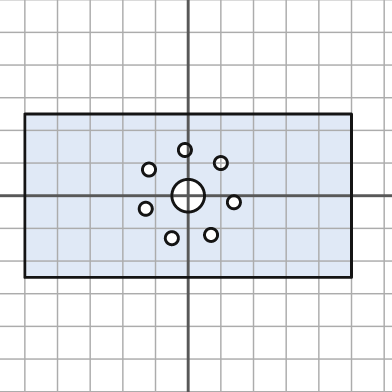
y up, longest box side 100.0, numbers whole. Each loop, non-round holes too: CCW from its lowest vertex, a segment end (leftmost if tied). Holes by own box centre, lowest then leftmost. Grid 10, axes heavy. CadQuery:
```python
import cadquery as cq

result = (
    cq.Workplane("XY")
    .moveTo(-50.0, -25.0)
    .lineTo(50.0, -25.0)
    .lineTo(50.0, 25.0)
    .lineTo(-50.0, 25.0)
    .close()
    .moveTo(-5.0, -13.0)
    .circle(2.0)
    .moveTo(7.0, -12.0)
    .circle(2.0)
    .moveTo(-13.0, -4.0)
    .circle(2.0)
    .moveTo(14.0, -2.0)
    .circle(2.0)
    .moveTo(0.0, 0.0)
    .circle(5.0)
    .moveTo(-12.0, 8.0)
    .circle(2.0)
    .moveTo(10.0, 10.0)
    .circle(2.0)
    .moveTo(-1.0, 14.0)
    .circle(2.0)
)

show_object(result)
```